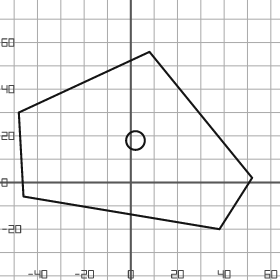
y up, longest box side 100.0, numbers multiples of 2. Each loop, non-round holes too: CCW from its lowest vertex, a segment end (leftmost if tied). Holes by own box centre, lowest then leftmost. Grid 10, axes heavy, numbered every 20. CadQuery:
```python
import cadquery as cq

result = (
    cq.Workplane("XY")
    .moveTo(38.0, -20.0)
    .lineTo(52.0, 2.0)
    .lineTo(8.0, 56.0)
    .lineTo(-48.0, 30.0)
    .lineTo(-46.0, -6.0)
    .close()
    .moveTo(2.0, 18.0)
    .circle(4.0)
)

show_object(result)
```